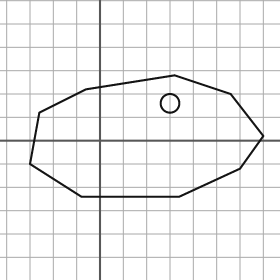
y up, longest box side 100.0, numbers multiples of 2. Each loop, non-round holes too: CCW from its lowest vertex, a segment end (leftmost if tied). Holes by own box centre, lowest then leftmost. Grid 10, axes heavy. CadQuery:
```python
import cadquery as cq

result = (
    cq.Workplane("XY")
    .moveTo(-8.0, -24.0)
    .lineTo(34.0, -24.0)
    .lineTo(60.0, -12.0)
    .lineTo(70.0, 2.0)
    .lineTo(56.0, 20.0)
    .lineTo(32.0, 28.0)
    .lineTo(-6.0, 22.0)
    .lineTo(-26.0, 12.0)
    .lineTo(-30.0, -10.0)
    .close()
    .moveTo(30.0, 16.0)
    .circle(4.0)
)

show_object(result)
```